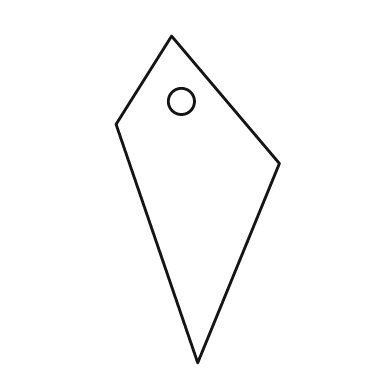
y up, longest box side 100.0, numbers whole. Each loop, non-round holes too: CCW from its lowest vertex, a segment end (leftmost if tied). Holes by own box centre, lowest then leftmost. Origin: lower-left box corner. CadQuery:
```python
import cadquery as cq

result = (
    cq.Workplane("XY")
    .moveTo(25.0, 0.0)
    .lineTo(50.0, 61.0)
    .lineTo(17.0, 100.0)
    .lineTo(0.0, 73.0)
    .close()
    .moveTo(20.0, 80.0)
    .circle(4.0)
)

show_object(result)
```